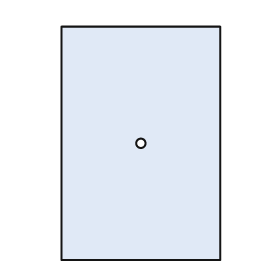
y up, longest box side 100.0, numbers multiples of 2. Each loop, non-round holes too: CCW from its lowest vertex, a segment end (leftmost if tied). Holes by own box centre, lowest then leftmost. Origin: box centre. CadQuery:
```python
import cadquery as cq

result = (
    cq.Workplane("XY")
    .moveTo(-34.0, -50.0)
    .lineTo(34.0, -50.0)
    .lineTo(34.0, 50.0)
    .lineTo(-34.0, 50.0)
    .close()
    .moveTo(0.0, 0.0)
    .circle(2.0)
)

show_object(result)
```